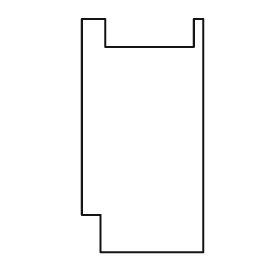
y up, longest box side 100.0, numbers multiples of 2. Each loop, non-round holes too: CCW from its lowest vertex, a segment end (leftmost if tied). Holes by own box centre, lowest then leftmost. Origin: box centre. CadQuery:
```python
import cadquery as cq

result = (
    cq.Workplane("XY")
    .moveTo(-18.0, -50.0)
    .lineTo(26.0, -50.0)
    .lineTo(26.0, 50.0)
    .lineTo(22.0, 50.0)
    .lineTo(22.0, 38.0)
    .lineTo(-16.0, 38.0)
    .lineTo(-16.0, 50.0)
    .lineTo(-26.0, 50.0)
    .lineTo(-26.0, -34.0)
    .lineTo(-18.0, -34.0)
    .close()
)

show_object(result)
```